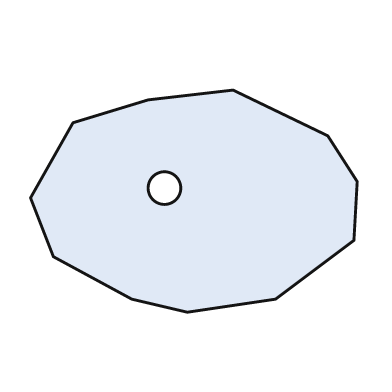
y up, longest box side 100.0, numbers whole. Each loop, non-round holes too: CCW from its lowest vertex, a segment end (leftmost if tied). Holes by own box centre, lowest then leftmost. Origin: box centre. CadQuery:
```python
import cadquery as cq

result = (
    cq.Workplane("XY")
    .moveTo(-2.0, -34.0)
    .lineTo(25.0, -30.0)
    .lineTo(49.0, -12.0)
    .lineTo(50.0, 6.0)
    .lineTo(41.0, 20.0)
    .lineTo(12.0, 34.0)
    .lineTo(-14.0, 31.0)
    .lineTo(-37.0, 24.0)
    .lineTo(-50.0, 1.0)
    .lineTo(-43.0, -17.0)
    .lineTo(-19.0, -30.0)
    .close()
    .moveTo(-9.0, 4.0)
    .circle(5.0)
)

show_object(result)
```